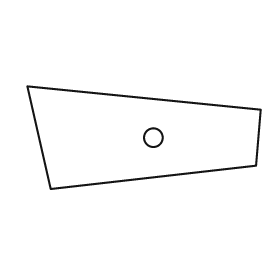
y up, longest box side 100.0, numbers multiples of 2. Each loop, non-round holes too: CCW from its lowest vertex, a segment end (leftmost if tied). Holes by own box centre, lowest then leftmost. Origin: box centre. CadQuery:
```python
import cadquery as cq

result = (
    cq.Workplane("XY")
    .moveTo(-40.0, -22.0)
    .lineTo(48.0, -12.0)
    .lineTo(50.0, 12.0)
    .lineTo(-50.0, 22.0)
    .close()
    .moveTo(4.0, 0.0)
    .circle(4.0)
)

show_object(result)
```